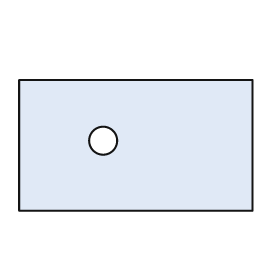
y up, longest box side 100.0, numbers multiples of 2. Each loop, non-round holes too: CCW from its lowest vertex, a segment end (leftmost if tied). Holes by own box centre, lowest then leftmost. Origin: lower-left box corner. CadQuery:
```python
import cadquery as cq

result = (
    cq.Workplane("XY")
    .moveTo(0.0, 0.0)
    .lineTo(100.0, 0.0)
    .lineTo(100.0, 56.0)
    .lineTo(0.0, 56.0)
    .close()
    .moveTo(36.0, 30.0)
    .circle(6.0)
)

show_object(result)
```